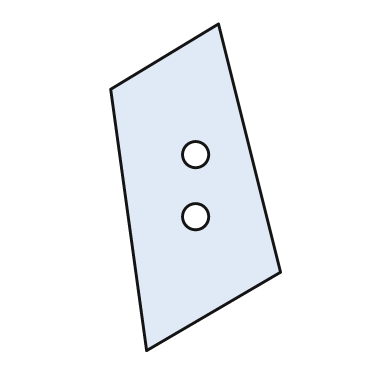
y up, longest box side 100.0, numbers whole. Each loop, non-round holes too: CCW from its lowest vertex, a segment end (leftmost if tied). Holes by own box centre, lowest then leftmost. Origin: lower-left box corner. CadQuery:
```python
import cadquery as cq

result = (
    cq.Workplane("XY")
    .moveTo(11.0, 0.0)
    .lineTo(52.0, 24.0)
    .lineTo(33.0, 100.0)
    .lineTo(0.0, 80.0)
    .close()
    .moveTo(26.0, 41.0)
    .circle(4.0)
    .moveTo(26.0, 60.0)
    .circle(4.0)
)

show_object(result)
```